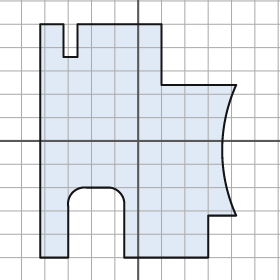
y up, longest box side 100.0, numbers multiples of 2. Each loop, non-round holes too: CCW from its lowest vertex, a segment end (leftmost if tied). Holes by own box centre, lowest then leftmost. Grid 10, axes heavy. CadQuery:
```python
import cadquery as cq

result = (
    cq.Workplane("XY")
    .moveTo(-42.0, -50.0)
    .lineTo(-30.0, -50.0)
    .lineTo(-30.0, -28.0)
    .threePointArc((-28.0, -22.0), (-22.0, -20.0))
    .lineTo(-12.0, -20.0)
    .threePointArc((-8.0, -22.0), (-6.0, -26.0))
    .lineTo(-6.0, -50.0)
    .lineTo(30.0, -50.0)
    .lineTo(30.0, -32.0)
    .lineTo(42.0, -32.0)
    .threePointArc((36.0, -4.0), (42.0, 24.0))
    .lineTo(10.0, 24.0)
    .lineTo(10.0, 50.0)
    .lineTo(-26.0, 50.0)
    .lineTo(-26.0, 36.0)
    .lineTo(-32.0, 36.0)
    .lineTo(-32.0, 50.0)
    .lineTo(-42.0, 50.0)
    .close()
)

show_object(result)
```